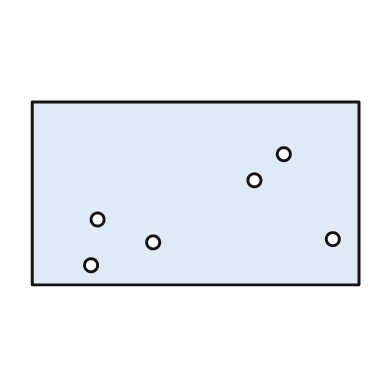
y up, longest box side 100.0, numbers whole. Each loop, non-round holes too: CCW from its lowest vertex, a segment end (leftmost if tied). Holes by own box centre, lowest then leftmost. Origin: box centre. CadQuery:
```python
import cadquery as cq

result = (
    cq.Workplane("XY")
    .moveTo(-50.0, -28.0)
    .lineTo(50.0, -28.0)
    .lineTo(50.0, 28.0)
    .lineTo(-50.0, 28.0)
    .close()
    .moveTo(-32.0, -22.0)
    .circle(2.0)
    .moveTo(-13.0, -15.0)
    .circle(2.0)
    .moveTo(42.0, -14.0)
    .circle(2.0)
    .moveTo(-30.0, -8.0)
    .circle(2.0)
    .moveTo(18.0, 4.0)
    .circle(2.0)
    .moveTo(27.0, 12.0)
    .circle(2.0)
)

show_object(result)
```